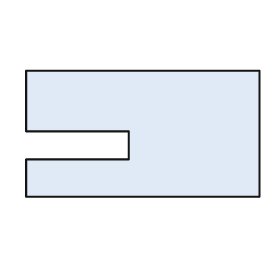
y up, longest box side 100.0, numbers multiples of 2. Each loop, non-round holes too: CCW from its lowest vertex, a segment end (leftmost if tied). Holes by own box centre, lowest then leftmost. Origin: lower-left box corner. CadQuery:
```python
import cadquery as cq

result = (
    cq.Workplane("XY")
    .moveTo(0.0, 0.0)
    .lineTo(100.0, 0.0)
    .lineTo(100.0, 54.0)
    .lineTo(0.0, 54.0)
    .lineTo(0.0, 28.0)
    .lineTo(44.0, 28.0)
    .lineTo(44.0, 16.0)
    .lineTo(0.0, 16.0)
    .close()
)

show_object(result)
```